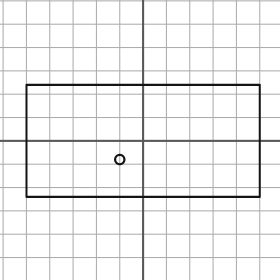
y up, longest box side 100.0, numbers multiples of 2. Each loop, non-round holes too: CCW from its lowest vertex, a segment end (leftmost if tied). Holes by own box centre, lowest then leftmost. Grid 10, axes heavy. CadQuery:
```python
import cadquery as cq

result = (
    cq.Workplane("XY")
    .moveTo(-50.0, -24.0)
    .lineTo(50.0, -24.0)
    .lineTo(50.0, 24.0)
    .lineTo(-50.0, 24.0)
    .close()
    .moveTo(-10.0, -8.0)
    .circle(2.0)
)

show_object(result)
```